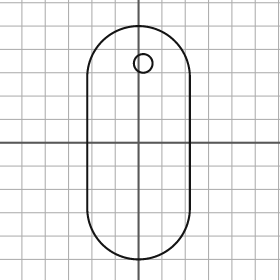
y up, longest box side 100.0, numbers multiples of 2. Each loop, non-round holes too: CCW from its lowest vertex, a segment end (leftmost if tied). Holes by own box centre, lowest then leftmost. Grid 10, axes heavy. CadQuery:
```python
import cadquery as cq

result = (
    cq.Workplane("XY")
    .moveTo(-22.0, -28.0)
    .threePointArc((0.0, -50.0), (22.0, -28.0))
    .lineTo(22.0, 28.0)
    .threePointArc((0.0, 50.0), (-22.0, 28.0))
    .close()
    .moveTo(2.0, 34.0)
    .circle(4.0)
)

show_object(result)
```